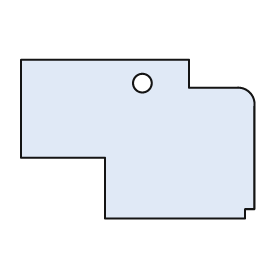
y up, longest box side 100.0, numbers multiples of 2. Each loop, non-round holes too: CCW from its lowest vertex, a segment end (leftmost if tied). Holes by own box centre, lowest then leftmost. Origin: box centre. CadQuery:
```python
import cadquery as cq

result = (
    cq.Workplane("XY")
    .moveTo(-14.0, -34.0)
    .lineTo(46.0, -34.0)
    .lineTo(46.0, -30.0)
    .lineTo(50.0, -30.0)
    .lineTo(50.0, 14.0)
    .threePointArc((48.0, 20.0), (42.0, 22.0))
    .lineTo(22.0, 22.0)
    .lineTo(22.0, 34.0)
    .lineTo(-50.0, 34.0)
    .lineTo(-50.0, -8.0)
    .lineTo(-14.0, -8.0)
    .close()
    .moveTo(2.0, 24.0)
    .circle(4.0)
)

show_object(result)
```